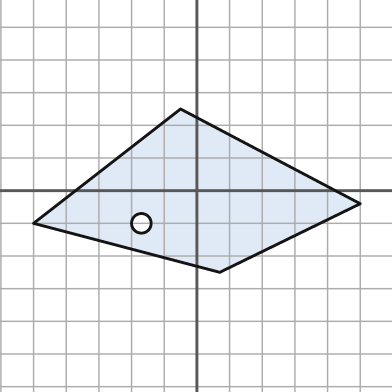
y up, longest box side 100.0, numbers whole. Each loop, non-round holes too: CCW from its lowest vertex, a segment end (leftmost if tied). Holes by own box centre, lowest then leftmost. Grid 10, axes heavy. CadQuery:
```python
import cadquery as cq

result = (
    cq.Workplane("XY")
    .moveTo(7.0, -25.0)
    .lineTo(50.0, -4.0)
    .lineTo(-5.0, 25.0)
    .lineTo(-50.0, -10.0)
    .close()
    .moveTo(-17.0, -10.0)
    .circle(3.0)
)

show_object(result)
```